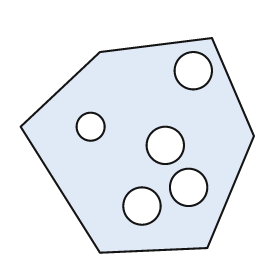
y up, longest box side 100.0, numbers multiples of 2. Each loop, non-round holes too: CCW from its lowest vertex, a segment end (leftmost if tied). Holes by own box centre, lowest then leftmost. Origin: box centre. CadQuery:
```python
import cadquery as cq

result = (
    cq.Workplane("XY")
    .moveTo(-16.0, -46.0)
    .lineTo(30.0, -44.0)
    .lineTo(50.0, 4.0)
    .lineTo(32.0, 46.0)
    .lineTo(-16.0, 40.0)
    .lineTo(-50.0, 8.0)
    .close()
    .moveTo(2.0, -26.0)
    .circle(8.0)
    .moveTo(22.0, -18.0)
    .circle(8.0)
    .moveTo(12.0, 0.0)
    .circle(8.0)
    .moveTo(-20.0, 8.0)
    .circle(6.0)
    .moveTo(24.0, 32.0)
    .circle(8.0)
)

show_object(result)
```